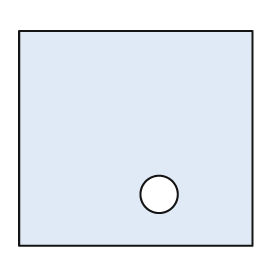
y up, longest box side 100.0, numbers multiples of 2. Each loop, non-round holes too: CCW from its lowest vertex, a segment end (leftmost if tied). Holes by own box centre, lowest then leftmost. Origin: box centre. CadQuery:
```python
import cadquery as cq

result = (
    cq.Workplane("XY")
    .moveTo(-50.0, -46.0)
    .lineTo(50.0, -46.0)
    .lineTo(50.0, 46.0)
    .lineTo(-50.0, 46.0)
    .close()
    .moveTo(10.0, -24.0)
    .circle(8.0)
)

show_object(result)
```